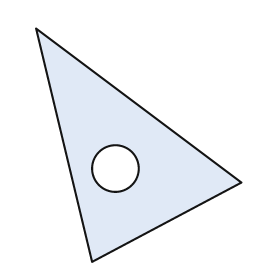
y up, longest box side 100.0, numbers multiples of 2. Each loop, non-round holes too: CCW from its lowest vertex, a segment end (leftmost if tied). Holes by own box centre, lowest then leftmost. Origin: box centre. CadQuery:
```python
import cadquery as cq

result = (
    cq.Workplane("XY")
    .moveTo(-20.0, -50.0)
    .lineTo(44.0, -16.0)
    .lineTo(-44.0, 50.0)
    .close()
    .moveTo(-10.0, -10.0)
    .circle(10.0)
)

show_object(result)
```